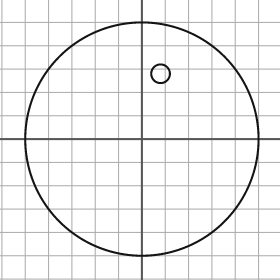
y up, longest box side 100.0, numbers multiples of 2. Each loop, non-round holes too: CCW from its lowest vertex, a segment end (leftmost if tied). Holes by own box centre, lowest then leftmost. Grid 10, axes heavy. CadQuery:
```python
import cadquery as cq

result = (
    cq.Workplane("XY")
    .moveTo(0.0, 0.0)
    .circle(50.0)
    .moveTo(8.0, 28.0)
    .circle(4.0)
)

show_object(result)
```